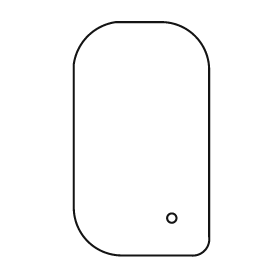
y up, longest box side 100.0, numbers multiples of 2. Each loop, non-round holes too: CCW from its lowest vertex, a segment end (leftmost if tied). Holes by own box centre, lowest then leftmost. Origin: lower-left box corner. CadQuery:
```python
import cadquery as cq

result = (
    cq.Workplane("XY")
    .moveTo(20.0, 0.0)
    .lineTo(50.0, 0.0)
    .threePointArc((56.0, 2.0), (58.0, 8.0))
    .lineTo(58.0, 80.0)
    .threePointArc((52.0, 94.0), (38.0, 100.0))
    .lineTo(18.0, 100.0)
    .threePointArc((6.0, 94.0), (0.0, 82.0))
    .lineTo(0.0, 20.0)
    .threePointArc((6.0, 6.0), (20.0, 0.0))
    .close()
    .moveTo(42.0, 16.0)
    .circle(2.0)
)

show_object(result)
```